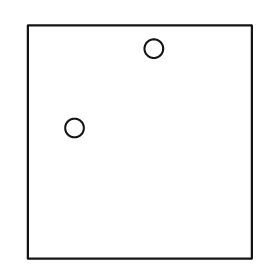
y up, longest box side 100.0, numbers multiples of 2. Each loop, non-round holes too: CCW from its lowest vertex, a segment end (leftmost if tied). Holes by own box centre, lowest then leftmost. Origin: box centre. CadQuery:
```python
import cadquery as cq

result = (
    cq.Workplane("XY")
    .moveTo(-48.0, -50.0)
    .lineTo(48.0, -50.0)
    .lineTo(48.0, 50.0)
    .lineTo(-48.0, 50.0)
    .close()
    .moveTo(-28.0, 6.0)
    .circle(4.0)
    .moveTo(6.0, 40.0)
    .circle(4.0)
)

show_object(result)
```